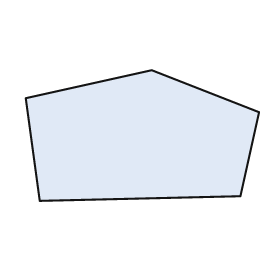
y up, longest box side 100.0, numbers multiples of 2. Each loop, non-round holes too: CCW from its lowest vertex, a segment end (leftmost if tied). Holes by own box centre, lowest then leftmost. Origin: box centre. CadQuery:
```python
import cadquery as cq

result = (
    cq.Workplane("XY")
    .moveTo(-44.0, -28.0)
    .lineTo(42.0, -26.0)
    .lineTo(50.0, 10.0)
    .lineTo(4.0, 28.0)
    .lineTo(-50.0, 16.0)
    .close()
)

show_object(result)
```